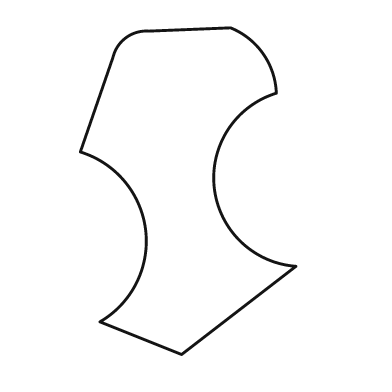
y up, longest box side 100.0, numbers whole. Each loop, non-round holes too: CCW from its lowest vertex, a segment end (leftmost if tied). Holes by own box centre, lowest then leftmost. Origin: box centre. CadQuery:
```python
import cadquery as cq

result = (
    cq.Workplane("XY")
    .moveTo(-2.0, -50.0)
    .lineTo(33.0, -23.0)
    .threePointArc((8.0, 1.0), (27.0, 30.0))
    .threePointArc((23.0, 42.0), (13.0, 50.0))
    .lineTo(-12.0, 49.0)
    .threePointArc((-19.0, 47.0), (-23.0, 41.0))
    .lineTo(-33.0, 12.0)
    .threePointArc((-13.0, -12.0), (-27.0, -40.0))
    .close()
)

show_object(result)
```